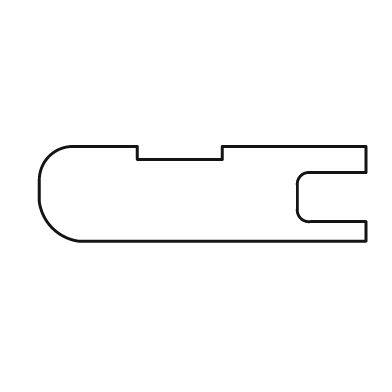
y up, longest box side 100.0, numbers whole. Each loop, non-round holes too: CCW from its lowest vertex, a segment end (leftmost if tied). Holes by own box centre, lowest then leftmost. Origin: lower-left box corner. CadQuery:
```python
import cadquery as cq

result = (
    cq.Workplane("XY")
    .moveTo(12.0, 0.0)
    .lineTo(100.0, 0.0)
    .lineTo(100.0, 6.0)
    .lineTo(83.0, 6.0)
    .threePointArc((80.0, 7.0), (79.0, 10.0))
    .lineTo(79.0, 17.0)
    .threePointArc((80.0, 20.0), (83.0, 21.0))
    .lineTo(100.0, 21.0)
    .lineTo(100.0, 29.0)
    .lineTo(56.0, 29.0)
    .lineTo(56.0, 25.0)
    .lineTo(30.0, 25.0)
    .lineTo(30.0, 29.0)
    .lineTo(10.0, 29.0)
    .threePointArc((3.0, 26.0), (0.0, 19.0))
    .lineTo(0.0, 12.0)
    .threePointArc((4.0, 4.0), (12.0, 0.0))
    .close()
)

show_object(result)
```